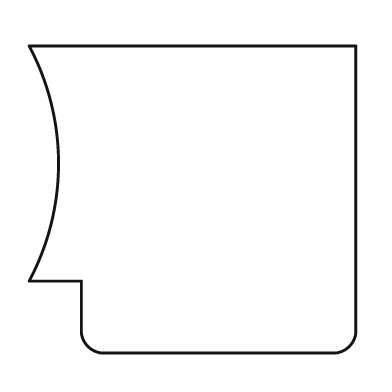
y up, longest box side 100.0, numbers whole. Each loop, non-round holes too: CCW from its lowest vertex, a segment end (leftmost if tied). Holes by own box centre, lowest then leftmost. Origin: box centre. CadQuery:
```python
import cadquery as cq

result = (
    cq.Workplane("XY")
    .moveTo(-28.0, -47.0)
    .lineTo(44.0, -47.0)
    .threePointArc((48.0, -45.0), (50.0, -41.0))
    .lineTo(50.0, 47.0)
    .lineTo(-50.0, 47.0)
    .threePointArc((-41.0, 11.0), (-50.0, -25.0))
    .lineTo(-34.0, -25.0)
    .lineTo(-34.0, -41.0)
    .threePointArc((-32.0, -45.0), (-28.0, -47.0))
    .close()
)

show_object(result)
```